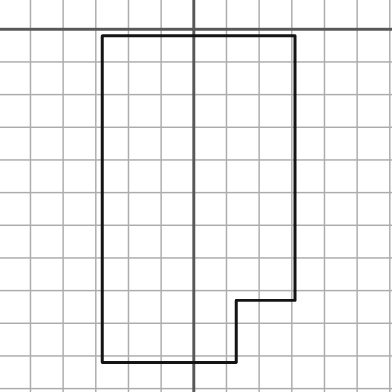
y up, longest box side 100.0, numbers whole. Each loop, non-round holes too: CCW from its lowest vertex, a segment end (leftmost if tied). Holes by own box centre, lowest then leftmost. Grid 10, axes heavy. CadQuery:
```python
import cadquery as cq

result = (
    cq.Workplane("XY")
    .moveTo(-28.0, -102.0)
    .lineTo(13.0, -102.0)
    .lineTo(13.0, -83.0)
    .lineTo(31.0, -83.0)
    .lineTo(31.0, -2.0)
    .lineTo(-28.0, -2.0)
    .close()
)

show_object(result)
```